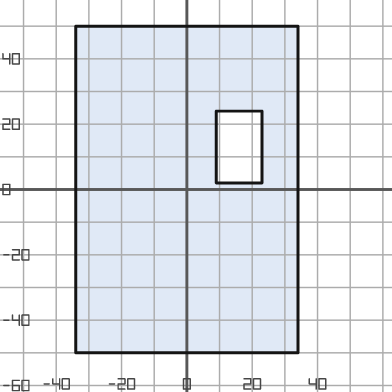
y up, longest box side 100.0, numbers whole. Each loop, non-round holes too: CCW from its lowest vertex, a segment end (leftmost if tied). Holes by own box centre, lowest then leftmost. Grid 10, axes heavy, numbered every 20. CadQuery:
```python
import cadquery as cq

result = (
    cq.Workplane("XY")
    .moveTo(-34.0, -50.0)
    .lineTo(34.0, -50.0)
    .lineTo(34.0, 50.0)
    .lineTo(-34.0, 50.0)
    .close()
    .moveTo(9.0, 2.0)
    .lineTo(23.0, 2.0)
    .lineTo(23.0, 24.0)
    .lineTo(9.0, 24.0)
    .close()
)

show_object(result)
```